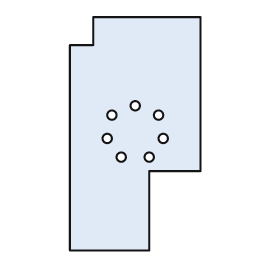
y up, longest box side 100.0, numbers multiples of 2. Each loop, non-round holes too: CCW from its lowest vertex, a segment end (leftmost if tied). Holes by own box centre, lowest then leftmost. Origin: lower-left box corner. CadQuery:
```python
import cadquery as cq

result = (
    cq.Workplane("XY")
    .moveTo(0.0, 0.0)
    .lineTo(34.0, 0.0)
    .lineTo(34.0, 34.0)
    .lineTo(56.0, 34.0)
    .lineTo(56.0, 100.0)
    .lineTo(10.0, 100.0)
    .lineTo(10.0, 88.0)
    .lineTo(0.0, 88.0)
    .close()
    .moveTo(22.0, 40.0)
    .circle(2.0)
    .moveTo(34.0, 40.0)
    .circle(2.0)
    .moveTo(16.0, 48.0)
    .circle(2.0)
    .moveTo(40.0, 48.0)
    .circle(2.0)
    .moveTo(18.0, 58.0)
    .circle(2.0)
    .moveTo(38.0, 58.0)
    .circle(2.0)
    .moveTo(28.0, 62.0)
    .circle(2.0)
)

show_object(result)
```